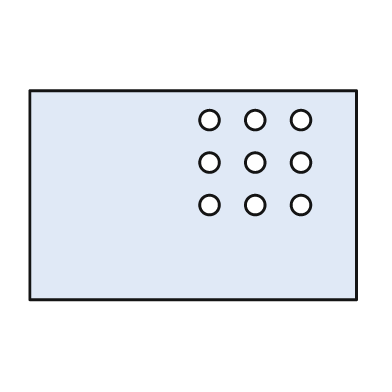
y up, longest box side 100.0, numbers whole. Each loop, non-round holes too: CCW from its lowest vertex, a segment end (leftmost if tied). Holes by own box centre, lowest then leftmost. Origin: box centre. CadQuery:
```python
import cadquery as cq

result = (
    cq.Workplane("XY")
    .moveTo(-50.0, -32.0)
    .lineTo(50.0, -32.0)
    .lineTo(50.0, 32.0)
    .lineTo(-50.0, 32.0)
    .close()
    .moveTo(5.0, -3.0)
    .circle(3.0)
    .moveTo(19.0, -3.0)
    .circle(3.0)
    .moveTo(33.0, -3.0)
    .circle(3.0)
    .moveTo(5.0, 10.0)
    .circle(3.0)
    .moveTo(19.0, 10.0)
    .circle(3.0)
    .moveTo(33.0, 10.0)
    .circle(3.0)
    .moveTo(5.0, 23.0)
    .circle(3.0)
    .moveTo(19.0, 23.0)
    .circle(3.0)
    .moveTo(33.0, 23.0)
    .circle(3.0)
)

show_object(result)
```